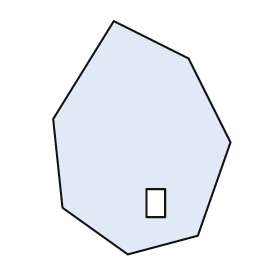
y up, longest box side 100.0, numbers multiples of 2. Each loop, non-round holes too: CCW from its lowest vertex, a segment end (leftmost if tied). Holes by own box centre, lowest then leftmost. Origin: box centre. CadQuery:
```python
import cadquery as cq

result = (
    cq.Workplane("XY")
    .moveTo(-6.0, -50.0)
    .lineTo(24.0, -42.0)
    .lineTo(38.0, -2.0)
    .lineTo(20.0, 34.0)
    .lineTo(-12.0, 50.0)
    .lineTo(-38.0, 8.0)
    .lineTo(-34.0, -30.0)
    .close()
    .moveTo(2.0, -34.0)
    .lineTo(10.0, -34.0)
    .lineTo(10.0, -22.0)
    .lineTo(2.0, -22.0)
    .close()
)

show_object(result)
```